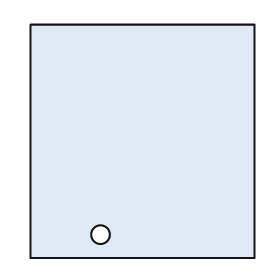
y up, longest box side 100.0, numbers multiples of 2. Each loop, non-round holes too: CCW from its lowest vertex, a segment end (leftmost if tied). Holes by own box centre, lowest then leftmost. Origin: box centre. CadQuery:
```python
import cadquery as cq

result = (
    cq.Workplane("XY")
    .moveTo(-48.0, -50.0)
    .lineTo(48.0, -50.0)
    .lineTo(48.0, 50.0)
    .lineTo(-48.0, 50.0)
    .close()
    .moveTo(-18.0, -40.0)
    .circle(4.0)
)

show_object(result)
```